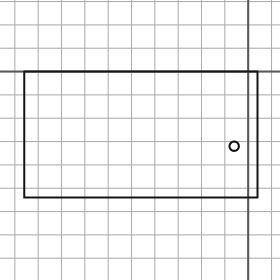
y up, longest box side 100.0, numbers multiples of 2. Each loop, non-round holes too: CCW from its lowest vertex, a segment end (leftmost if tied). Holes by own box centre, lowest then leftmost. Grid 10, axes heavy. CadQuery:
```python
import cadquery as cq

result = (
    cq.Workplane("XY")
    .moveTo(-96.0, -54.0)
    .lineTo(4.0, -54.0)
    .lineTo(4.0, 0.0)
    .lineTo(-96.0, 0.0)
    .close()
    .moveTo(-6.0, -32.0)
    .circle(2.0)
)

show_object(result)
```